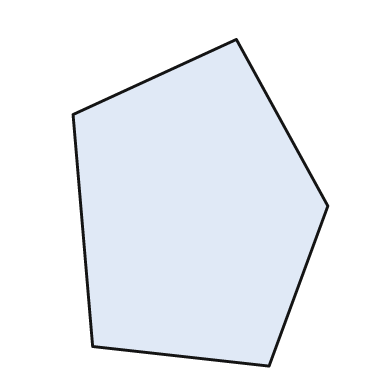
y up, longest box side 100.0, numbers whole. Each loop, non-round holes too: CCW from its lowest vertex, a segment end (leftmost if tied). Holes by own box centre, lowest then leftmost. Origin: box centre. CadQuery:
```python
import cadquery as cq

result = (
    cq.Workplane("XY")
    .moveTo(21.0, -50.0)
    .lineTo(39.0, -1.0)
    .lineTo(11.0, 50.0)
    .lineTo(-39.0, 27.0)
    .lineTo(-33.0, -44.0)
    .close()
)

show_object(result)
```